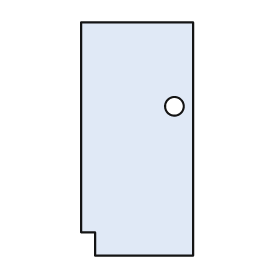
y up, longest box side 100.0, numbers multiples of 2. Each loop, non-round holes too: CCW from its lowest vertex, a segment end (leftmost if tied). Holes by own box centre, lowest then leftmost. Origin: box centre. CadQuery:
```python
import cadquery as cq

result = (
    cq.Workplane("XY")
    .moveTo(-18.0, -50.0)
    .lineTo(24.0, -50.0)
    .lineTo(24.0, 50.0)
    .lineTo(-24.0, 50.0)
    .lineTo(-24.0, -40.0)
    .lineTo(-18.0, -40.0)
    .close()
    .moveTo(16.0, 14.0)
    .circle(4.0)
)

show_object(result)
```